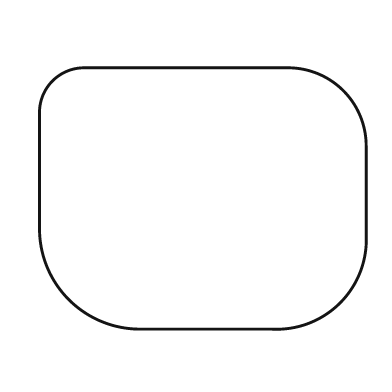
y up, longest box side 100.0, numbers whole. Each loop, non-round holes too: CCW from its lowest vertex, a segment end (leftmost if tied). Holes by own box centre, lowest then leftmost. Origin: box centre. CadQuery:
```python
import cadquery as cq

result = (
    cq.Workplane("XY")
    .moveTo(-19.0, -40.0)
    .lineTo(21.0, -40.0)
    .threePointArc((42.0, -32.0), (50.0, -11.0))
    .lineTo(50.0, 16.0)
    .threePointArc((43.0, 33.0), (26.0, 40.0))
    .lineTo(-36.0, 40.0)
    .threePointArc((-46.0, 36.0), (-50.0, 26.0))
    .lineTo(-50.0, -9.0)
    .threePointArc((-41.0, -31.0), (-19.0, -40.0))
    .close()
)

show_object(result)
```